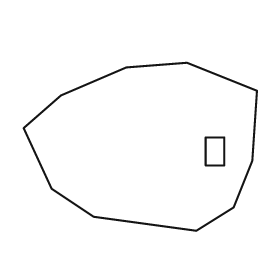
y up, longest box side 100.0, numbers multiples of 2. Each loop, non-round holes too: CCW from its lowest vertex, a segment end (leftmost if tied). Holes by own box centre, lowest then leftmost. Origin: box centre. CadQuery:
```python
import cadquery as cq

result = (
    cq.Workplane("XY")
    .moveTo(24.0, -36.0)
    .lineTo(40.0, -26.0)
    .lineTo(48.0, -6.0)
    .lineTo(50.0, 24.0)
    .lineTo(20.0, 36.0)
    .lineTo(-6.0, 34.0)
    .lineTo(-34.0, 22.0)
    .lineTo(-50.0, 8.0)
    .lineTo(-38.0, -18.0)
    .lineTo(-20.0, -30.0)
    .close()
    .moveTo(28.0, -8.0)
    .lineTo(36.0, -8.0)
    .lineTo(36.0, 4.0)
    .lineTo(28.0, 4.0)
    .close()
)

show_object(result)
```